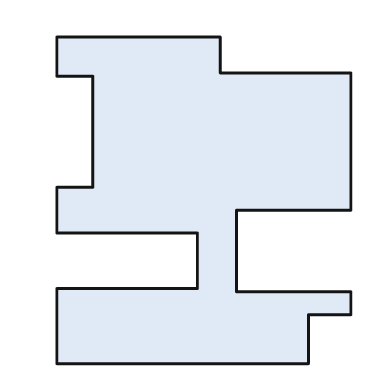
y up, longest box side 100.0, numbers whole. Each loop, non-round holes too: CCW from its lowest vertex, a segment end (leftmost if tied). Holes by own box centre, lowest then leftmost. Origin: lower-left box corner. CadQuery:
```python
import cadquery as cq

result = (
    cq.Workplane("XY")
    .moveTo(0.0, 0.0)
    .lineTo(77.0, 0.0)
    .lineTo(77.0, 15.0)
    .lineTo(90.0, 15.0)
    .lineTo(90.0, 22.0)
    .lineTo(55.0, 22.0)
    .lineTo(55.0, 47.0)
    .lineTo(90.0, 47.0)
    .lineTo(90.0, 89.0)
    .lineTo(50.0, 89.0)
    .lineTo(50.0, 100.0)
    .lineTo(0.0, 100.0)
    .lineTo(0.0, 88.0)
    .lineTo(11.0, 88.0)
    .lineTo(11.0, 54.0)
    .lineTo(0.0, 54.0)
    .lineTo(0.0, 40.0)
    .lineTo(43.0, 40.0)
    .lineTo(43.0, 23.0)
    .lineTo(0.0, 23.0)
    .close()
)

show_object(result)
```